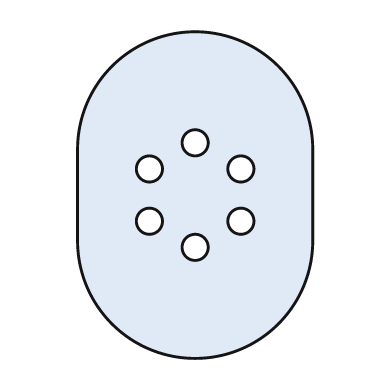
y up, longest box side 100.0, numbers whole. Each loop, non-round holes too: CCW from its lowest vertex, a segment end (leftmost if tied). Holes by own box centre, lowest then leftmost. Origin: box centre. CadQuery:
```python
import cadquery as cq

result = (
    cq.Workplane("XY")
    .moveTo(-36.0, -14.0)
    .threePointArc((0.0, -50.0), (36.0, -14.0))
    .lineTo(36.0, 14.0)
    .threePointArc((0.0, 50.0), (-36.0, 14.0))
    .close()
    .moveTo(0.0, -16.0)
    .circle(4.0)
    .moveTo(-14.0, -8.0)
    .circle(4.0)
    .moveTo(14.0, -8.0)
    .circle(4.0)
    .moveTo(-14.0, 8.0)
    .circle(4.0)
    .moveTo(14.0, 8.0)
    .circle(4.0)
    .moveTo(0.0, 16.0)
    .circle(4.0)
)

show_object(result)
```